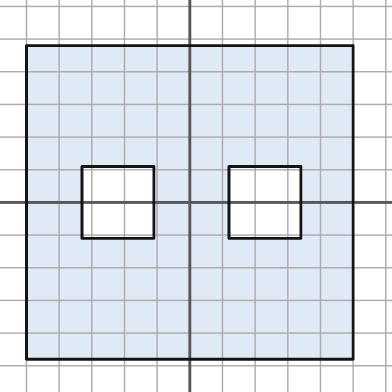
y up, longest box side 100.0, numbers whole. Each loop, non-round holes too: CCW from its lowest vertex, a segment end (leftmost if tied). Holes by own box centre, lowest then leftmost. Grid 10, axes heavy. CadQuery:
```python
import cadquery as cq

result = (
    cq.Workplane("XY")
    .moveTo(-50.0, -48.0)
    .lineTo(50.0, -48.0)
    .lineTo(50.0, 48.0)
    .lineTo(-50.0, 48.0)
    .close()
    .moveTo(-33.0, -11.0)
    .lineTo(-11.0, -11.0)
    .lineTo(-11.0, 11.0)
    .lineTo(-33.0, 11.0)
    .close()
    .moveTo(12.0, -11.0)
    .lineTo(34.0, -11.0)
    .lineTo(34.0, 11.0)
    .lineTo(12.0, 11.0)
    .close()
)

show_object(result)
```